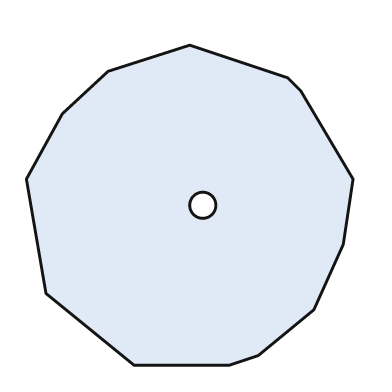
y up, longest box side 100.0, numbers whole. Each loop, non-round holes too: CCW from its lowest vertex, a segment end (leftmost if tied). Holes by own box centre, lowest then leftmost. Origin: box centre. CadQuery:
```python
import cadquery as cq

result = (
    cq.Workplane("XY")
    .moveTo(-17.0, -49.0)
    .lineTo(12.0, -49.0)
    .lineTo(21.0, -46.0)
    .lineTo(38.0, -32.0)
    .lineTo(47.0, -12.0)
    .lineTo(50.0, 8.0)
    .lineTo(34.0, 35.0)
    .lineTo(30.0, 39.0)
    .lineTo(0.0, 49.0)
    .lineTo(-25.0, 41.0)
    .lineTo(-39.0, 28.0)
    .lineTo(-50.0, 8.0)
    .lineTo(-44.0, -27.0)
    .close()
    .moveTo(4.0, 0.0)
    .circle(4.0)
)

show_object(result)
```